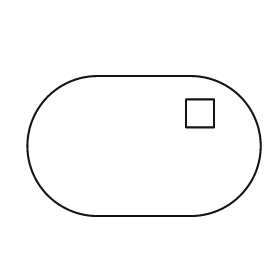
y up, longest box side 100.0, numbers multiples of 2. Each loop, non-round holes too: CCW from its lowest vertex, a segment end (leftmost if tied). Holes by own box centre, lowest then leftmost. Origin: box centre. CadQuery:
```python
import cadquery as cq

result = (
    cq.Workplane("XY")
    .moveTo(-20.0, -30.0)
    .lineTo(20.0, -30.0)
    .threePointArc((50.0, 0.0), (20.0, 30.0))
    .lineTo(-20.0, 30.0)
    .threePointArc((-50.0, 0.0), (-20.0, -30.0))
    .close()
    .moveTo(18.0, 8.0)
    .lineTo(30.0, 8.0)
    .lineTo(30.0, 20.0)
    .lineTo(18.0, 20.0)
    .close()
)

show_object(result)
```